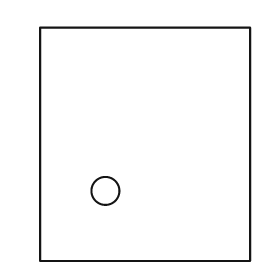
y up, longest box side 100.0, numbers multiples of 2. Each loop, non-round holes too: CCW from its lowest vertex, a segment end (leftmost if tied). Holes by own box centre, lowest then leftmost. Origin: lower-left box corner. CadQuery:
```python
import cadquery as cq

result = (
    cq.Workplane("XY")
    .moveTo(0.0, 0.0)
    .lineTo(90.0, 0.0)
    .lineTo(90.0, 100.0)
    .lineTo(0.0, 100.0)
    .close()
    .moveTo(28.0, 30.0)
    .circle(6.0)
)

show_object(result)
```